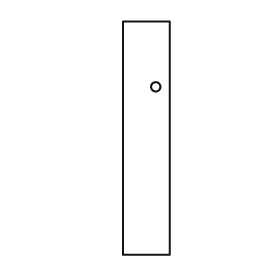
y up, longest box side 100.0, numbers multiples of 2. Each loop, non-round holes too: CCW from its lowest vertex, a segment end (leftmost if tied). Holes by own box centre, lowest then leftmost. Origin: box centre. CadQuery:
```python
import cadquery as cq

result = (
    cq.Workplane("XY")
    .moveTo(-10.0, -50.0)
    .lineTo(10.0, -50.0)
    .lineTo(10.0, 50.0)
    .lineTo(-10.0, 50.0)
    .close()
    .moveTo(4.0, 22.0)
    .circle(2.0)
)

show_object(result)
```